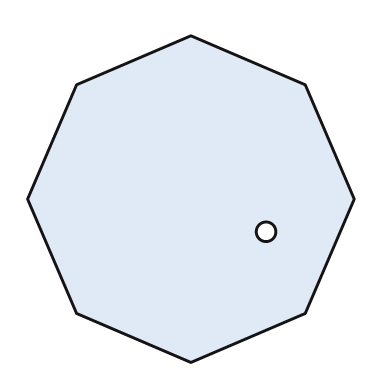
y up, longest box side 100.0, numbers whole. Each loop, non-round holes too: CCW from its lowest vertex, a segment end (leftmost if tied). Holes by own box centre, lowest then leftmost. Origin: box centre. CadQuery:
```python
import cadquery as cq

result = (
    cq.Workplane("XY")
    .moveTo(0.0, -50.0)
    .lineTo(35.0, -35.0)
    .lineTo(50.0, 0.0)
    .lineTo(35.0, 35.0)
    .lineTo(0.0, 50.0)
    .lineTo(-35.0, 35.0)
    .lineTo(-50.0, 0.0)
    .lineTo(-35.0, -35.0)
    .close()
    .moveTo(23.0, -10.0)
    .circle(3.0)
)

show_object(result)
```